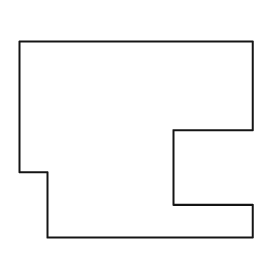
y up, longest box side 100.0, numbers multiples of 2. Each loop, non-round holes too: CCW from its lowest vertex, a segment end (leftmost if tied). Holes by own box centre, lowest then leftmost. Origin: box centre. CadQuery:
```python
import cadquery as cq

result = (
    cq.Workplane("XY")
    .moveTo(-38.0, -42.0)
    .lineTo(50.0, -42.0)
    .lineTo(50.0, -28.0)
    .lineTo(16.0, -28.0)
    .lineTo(16.0, 4.0)
    .lineTo(50.0, 4.0)
    .lineTo(50.0, 42.0)
    .lineTo(-50.0, 42.0)
    .lineTo(-50.0, -14.0)
    .lineTo(-38.0, -14.0)
    .close()
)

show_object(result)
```